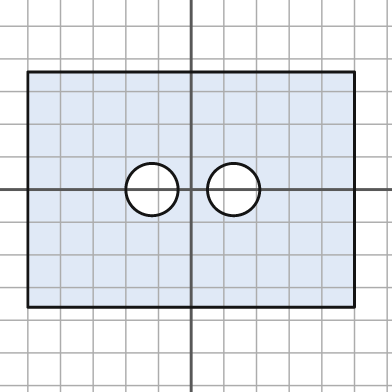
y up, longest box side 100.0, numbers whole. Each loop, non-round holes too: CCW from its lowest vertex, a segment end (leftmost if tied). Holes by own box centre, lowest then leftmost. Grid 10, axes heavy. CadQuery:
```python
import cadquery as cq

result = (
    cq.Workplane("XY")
    .moveTo(-50.0, -36.0)
    .lineTo(50.0, -36.0)
    .lineTo(50.0, 36.0)
    .lineTo(-50.0, 36.0)
    .close()
    .moveTo(-12.0, 0.0)
    .circle(8.0)
    .moveTo(13.0, 0.0)
    .circle(8.0)
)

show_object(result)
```